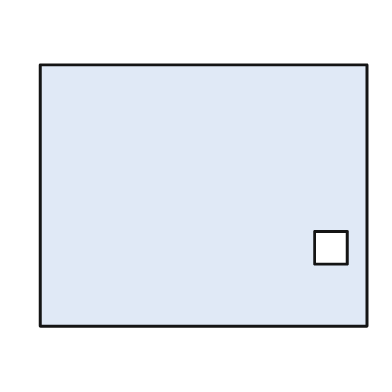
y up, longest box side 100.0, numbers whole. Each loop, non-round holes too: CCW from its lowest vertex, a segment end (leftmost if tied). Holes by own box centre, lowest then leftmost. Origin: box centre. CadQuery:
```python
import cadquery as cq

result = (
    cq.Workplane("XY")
    .moveTo(-50.0, -40.0)
    .lineTo(50.0, -40.0)
    .lineTo(50.0, 40.0)
    .lineTo(-50.0, 40.0)
    .close()
    .moveTo(34.0, -21.0)
    .lineTo(44.0, -21.0)
    .lineTo(44.0, -11.0)
    .lineTo(34.0, -11.0)
    .close()
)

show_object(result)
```